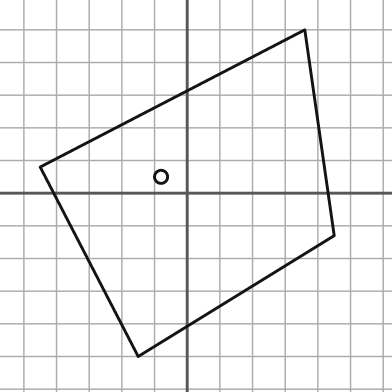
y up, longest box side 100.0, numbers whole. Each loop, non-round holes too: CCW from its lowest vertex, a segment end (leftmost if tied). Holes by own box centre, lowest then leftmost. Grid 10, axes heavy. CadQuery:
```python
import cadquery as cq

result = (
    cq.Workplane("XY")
    .moveTo(-15.0, -50.0)
    .lineTo(45.0, -13.0)
    .lineTo(36.0, 50.0)
    .lineTo(-45.0, 8.0)
    .close()
    .moveTo(-8.0, 5.0)
    .circle(2.0)
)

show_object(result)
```